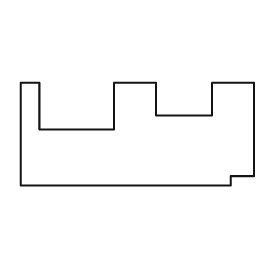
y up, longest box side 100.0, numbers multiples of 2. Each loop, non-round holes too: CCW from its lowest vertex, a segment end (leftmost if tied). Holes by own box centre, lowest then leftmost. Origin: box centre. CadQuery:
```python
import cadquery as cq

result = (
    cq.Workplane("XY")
    .moveTo(-50.0, -22.0)
    .lineTo(40.0, -22.0)
    .lineTo(40.0, -18.0)
    .lineTo(50.0, -18.0)
    .lineTo(50.0, 22.0)
    .lineTo(32.0, 22.0)
    .lineTo(32.0, 8.0)
    .lineTo(8.0, 8.0)
    .lineTo(8.0, 22.0)
    .lineTo(-10.0, 22.0)
    .lineTo(-10.0, 2.0)
    .lineTo(-42.0, 2.0)
    .lineTo(-42.0, 22.0)
    .lineTo(-50.0, 22.0)
    .close()
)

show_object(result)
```